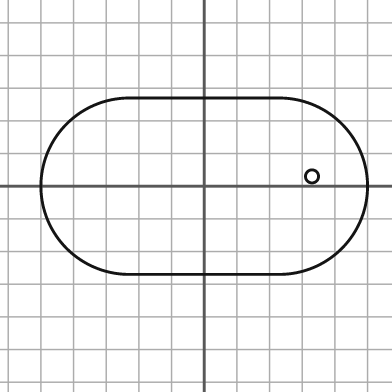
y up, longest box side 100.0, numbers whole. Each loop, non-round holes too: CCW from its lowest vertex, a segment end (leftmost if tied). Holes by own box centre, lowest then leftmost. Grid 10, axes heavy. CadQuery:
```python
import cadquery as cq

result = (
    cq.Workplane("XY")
    .moveTo(-23.0, -27.0)
    .lineTo(23.0, -27.0)
    .threePointArc((50.0, 0.0), (23.0, 27.0))
    .lineTo(-23.0, 27.0)
    .threePointArc((-50.0, 0.0), (-23.0, -27.0))
    .close()
    .moveTo(33.0, 3.0)
    .circle(2.0)
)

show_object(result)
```